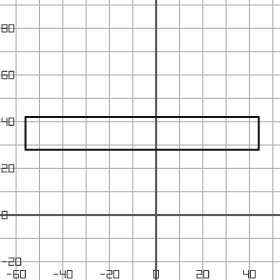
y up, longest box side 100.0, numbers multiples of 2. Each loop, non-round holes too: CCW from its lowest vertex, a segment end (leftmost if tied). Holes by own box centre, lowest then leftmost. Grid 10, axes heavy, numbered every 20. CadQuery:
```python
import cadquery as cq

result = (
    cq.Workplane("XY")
    .moveTo(-56.0, 28.0)
    .lineTo(44.0, 28.0)
    .lineTo(44.0, 42.0)
    .lineTo(-56.0, 42.0)
    .close()
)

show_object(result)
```